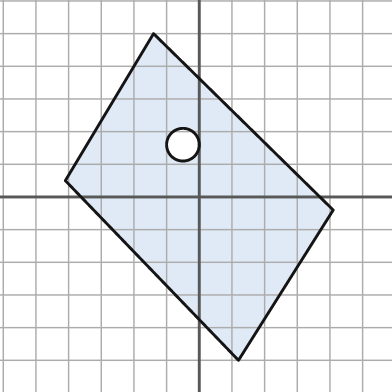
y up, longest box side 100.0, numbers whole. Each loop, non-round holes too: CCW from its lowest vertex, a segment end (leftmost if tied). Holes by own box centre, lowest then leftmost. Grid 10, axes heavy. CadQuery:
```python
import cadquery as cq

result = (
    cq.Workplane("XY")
    .moveTo(12.0, -50.0)
    .lineTo(41.0, -4.0)
    .lineTo(-14.0, 50.0)
    .lineTo(-41.0, 5.0)
    .close()
    .moveTo(-5.0, 16.0)
    .circle(5.0)
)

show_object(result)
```